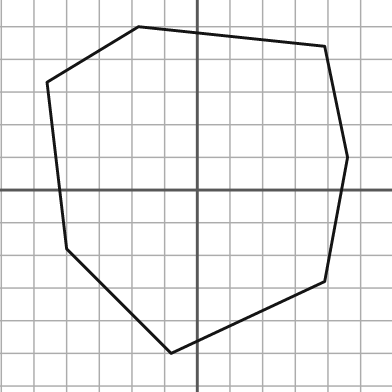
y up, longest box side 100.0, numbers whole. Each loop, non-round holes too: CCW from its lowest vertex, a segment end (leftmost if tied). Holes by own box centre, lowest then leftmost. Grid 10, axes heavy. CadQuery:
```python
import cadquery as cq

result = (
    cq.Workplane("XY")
    .moveTo(-8.0, -50.0)
    .lineTo(39.0, -28.0)
    .lineTo(46.0, 10.0)
    .lineTo(39.0, 44.0)
    .lineTo(-18.0, 50.0)
    .lineTo(-46.0, 33.0)
    .lineTo(-40.0, -18.0)
    .close()
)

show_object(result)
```